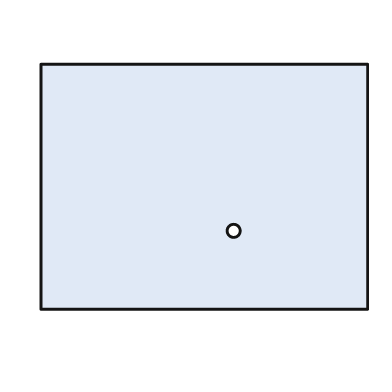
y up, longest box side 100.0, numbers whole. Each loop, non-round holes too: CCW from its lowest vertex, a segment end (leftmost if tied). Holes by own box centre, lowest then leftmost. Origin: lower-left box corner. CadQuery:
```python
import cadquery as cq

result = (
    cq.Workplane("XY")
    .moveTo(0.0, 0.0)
    .lineTo(100.0, 0.0)
    .lineTo(100.0, 75.0)
    .lineTo(0.0, 75.0)
    .close()
    .moveTo(59.0, 24.0)
    .circle(2.0)
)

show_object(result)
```